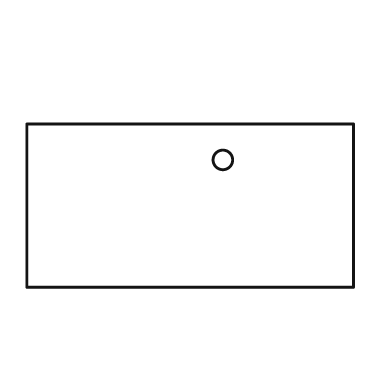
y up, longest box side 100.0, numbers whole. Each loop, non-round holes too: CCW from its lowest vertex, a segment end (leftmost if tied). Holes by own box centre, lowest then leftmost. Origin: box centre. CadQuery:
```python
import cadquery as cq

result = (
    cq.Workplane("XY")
    .moveTo(-50.0, -25.0)
    .lineTo(50.0, -25.0)
    .lineTo(50.0, 25.0)
    .lineTo(-50.0, 25.0)
    .close()
    .moveTo(10.0, 14.0)
    .circle(3.0)
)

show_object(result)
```